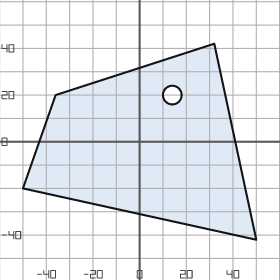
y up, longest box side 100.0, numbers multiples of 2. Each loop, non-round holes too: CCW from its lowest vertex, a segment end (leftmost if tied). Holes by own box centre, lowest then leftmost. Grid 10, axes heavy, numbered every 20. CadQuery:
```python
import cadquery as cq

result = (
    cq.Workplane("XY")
    .moveTo(50.0, -42.0)
    .lineTo(32.0, 42.0)
    .lineTo(-36.0, 20.0)
    .lineTo(-50.0, -20.0)
    .close()
    .moveTo(14.0, 20.0)
    .circle(4.0)
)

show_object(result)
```